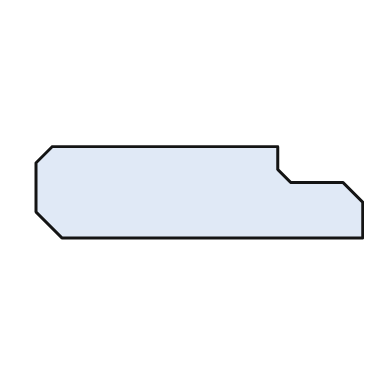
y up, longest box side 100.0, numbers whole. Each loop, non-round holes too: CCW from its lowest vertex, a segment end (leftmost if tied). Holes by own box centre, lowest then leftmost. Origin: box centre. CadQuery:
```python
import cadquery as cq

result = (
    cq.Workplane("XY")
    .moveTo(-42.0, -14.0)
    .lineTo(50.0, -14.0)
    .lineTo(50.0, -3.0)
    .lineTo(44.0, 3.0)
    .lineTo(28.0, 3.0)
    .lineTo(24.0, 7.0)
    .lineTo(24.0, 14.0)
    .lineTo(-45.0, 14.0)
    .lineTo(-50.0, 9.0)
    .lineTo(-50.0, -6.0)
    .close()
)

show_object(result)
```